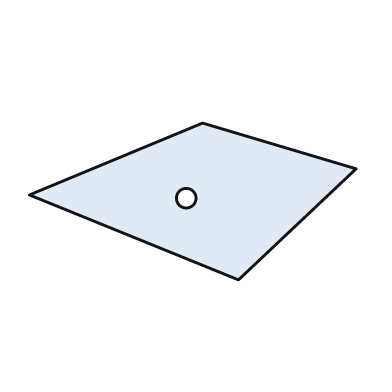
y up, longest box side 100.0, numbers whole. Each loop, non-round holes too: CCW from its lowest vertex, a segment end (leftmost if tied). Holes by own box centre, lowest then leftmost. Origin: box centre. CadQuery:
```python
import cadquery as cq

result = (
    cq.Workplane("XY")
    .moveTo(14.0, -24.0)
    .lineTo(50.0, 10.0)
    .lineTo(3.0, 24.0)
    .lineTo(-50.0, 2.0)
    .close()
    .moveTo(-2.0, 1.0)
    .circle(3.0)
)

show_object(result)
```